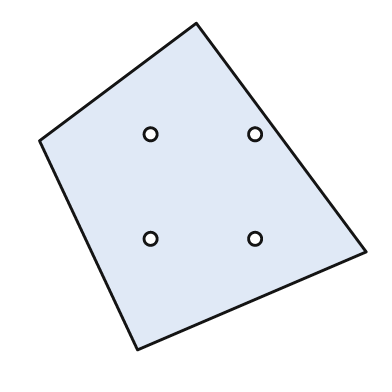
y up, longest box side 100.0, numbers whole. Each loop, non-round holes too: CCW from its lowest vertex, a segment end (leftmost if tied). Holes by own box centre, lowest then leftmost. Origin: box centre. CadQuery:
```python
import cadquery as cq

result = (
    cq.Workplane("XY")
    .moveTo(-20.0, -50.0)
    .lineTo(50.0, -20.0)
    .lineTo(-2.0, 50.0)
    .lineTo(-50.0, 14.0)
    .close()
    .moveTo(-16.0, -16.0)
    .circle(2.0)
    .moveTo(16.0, -16.0)
    .circle(2.0)
    .moveTo(-16.0, 16.0)
    .circle(2.0)
    .moveTo(16.0, 16.0)
    .circle(2.0)
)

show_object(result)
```